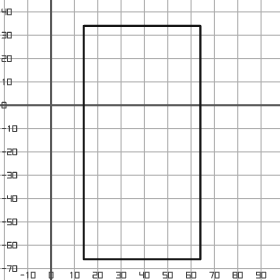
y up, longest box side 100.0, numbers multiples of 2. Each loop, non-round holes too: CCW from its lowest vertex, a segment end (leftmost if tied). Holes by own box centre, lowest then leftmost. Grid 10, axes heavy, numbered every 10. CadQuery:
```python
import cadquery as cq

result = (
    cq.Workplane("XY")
    .moveTo(14.0, -66.0)
    .lineTo(64.0, -66.0)
    .lineTo(64.0, 34.0)
    .lineTo(14.0, 34.0)
    .close()
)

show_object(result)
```